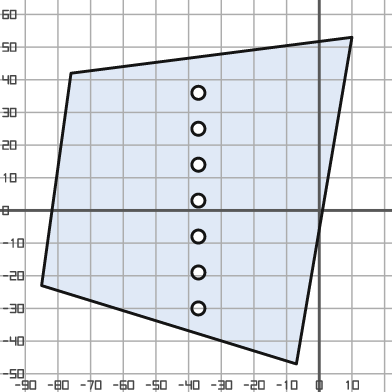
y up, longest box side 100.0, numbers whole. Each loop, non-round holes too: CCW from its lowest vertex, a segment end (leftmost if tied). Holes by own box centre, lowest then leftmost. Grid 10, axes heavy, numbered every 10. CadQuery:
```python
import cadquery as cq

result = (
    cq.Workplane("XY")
    .moveTo(-7.0, -47.0)
    .lineTo(10.0, 53.0)
    .lineTo(-76.0, 42.0)
    .lineTo(-85.0, -23.0)
    .close()
    .moveTo(-37.0, -30.0)
    .circle(2.0)
    .moveTo(-37.0, -19.0)
    .circle(2.0)
    .moveTo(-37.0, -8.0)
    .circle(2.0)
    .moveTo(-37.0, 3.0)
    .circle(2.0)
    .moveTo(-37.0, 14.0)
    .circle(2.0)
    .moveTo(-37.0, 25.0)
    .circle(2.0)
    .moveTo(-37.0, 36.0)
    .circle(2.0)
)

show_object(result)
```